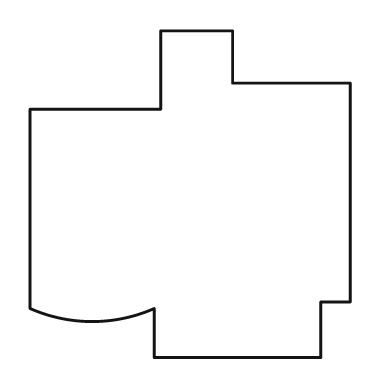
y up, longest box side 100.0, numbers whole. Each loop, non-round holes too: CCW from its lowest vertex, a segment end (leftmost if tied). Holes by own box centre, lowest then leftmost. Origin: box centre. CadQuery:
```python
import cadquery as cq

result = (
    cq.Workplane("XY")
    .moveTo(-11.0, -50.0)
    .lineTo(40.0, -50.0)
    .lineTo(40.0, -33.0)
    .lineTo(49.0, -33.0)
    .lineTo(49.0, 34.0)
    .lineTo(13.0, 34.0)
    .lineTo(13.0, 50.0)
    .lineTo(-9.0, 50.0)
    .lineTo(-9.0, 26.0)
    .lineTo(-49.0, 26.0)
    .lineTo(-49.0, -35.0)
    .threePointArc((-30.0, -39.0), (-11.0, -35.0))
    .close()
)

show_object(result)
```